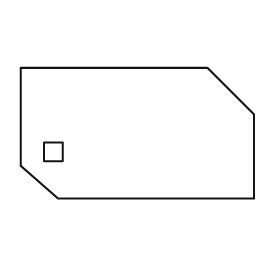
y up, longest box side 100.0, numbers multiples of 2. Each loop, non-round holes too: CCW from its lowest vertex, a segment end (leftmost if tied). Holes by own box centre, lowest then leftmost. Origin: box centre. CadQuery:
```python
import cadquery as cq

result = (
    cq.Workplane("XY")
    .moveTo(-34.0, -28.0)
    .lineTo(50.0, -28.0)
    .lineTo(50.0, 8.0)
    .lineTo(30.0, 28.0)
    .lineTo(-50.0, 28.0)
    .lineTo(-50.0, -14.0)
    .close()
    .moveTo(-40.0, -12.0)
    .lineTo(-32.0, -12.0)
    .lineTo(-32.0, -4.0)
    .lineTo(-40.0, -4.0)
    .close()
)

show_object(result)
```